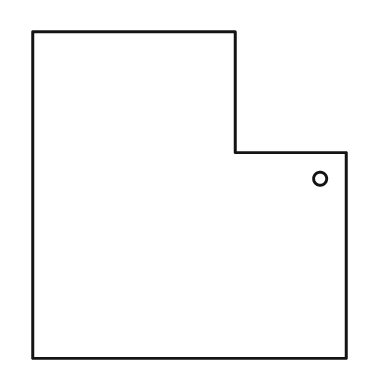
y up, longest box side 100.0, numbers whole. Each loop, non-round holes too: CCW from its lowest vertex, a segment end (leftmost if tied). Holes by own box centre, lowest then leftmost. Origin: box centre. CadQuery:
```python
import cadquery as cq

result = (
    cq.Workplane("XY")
    .moveTo(-48.0, -50.0)
    .lineTo(48.0, -50.0)
    .lineTo(48.0, 13.0)
    .lineTo(14.0, 13.0)
    .lineTo(14.0, 50.0)
    .lineTo(-48.0, 50.0)
    .close()
    .moveTo(40.0, 5.0)
    .circle(2.0)
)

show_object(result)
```